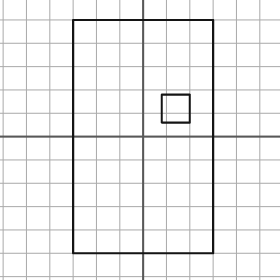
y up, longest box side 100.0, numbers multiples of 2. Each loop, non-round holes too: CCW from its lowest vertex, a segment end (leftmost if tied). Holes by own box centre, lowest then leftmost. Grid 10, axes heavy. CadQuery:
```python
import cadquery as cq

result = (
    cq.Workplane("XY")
    .moveTo(-30.0, -50.0)
    .lineTo(30.0, -50.0)
    .lineTo(30.0, 50.0)
    .lineTo(-30.0, 50.0)
    .close()
    .moveTo(8.0, 6.0)
    .lineTo(20.0, 6.0)
    .lineTo(20.0, 18.0)
    .lineTo(8.0, 18.0)
    .close()
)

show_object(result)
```